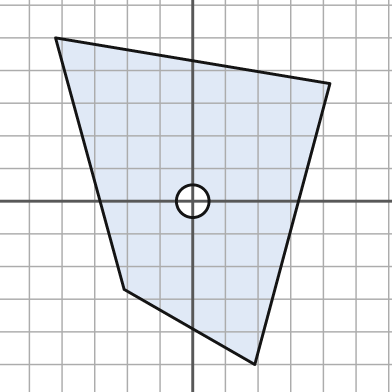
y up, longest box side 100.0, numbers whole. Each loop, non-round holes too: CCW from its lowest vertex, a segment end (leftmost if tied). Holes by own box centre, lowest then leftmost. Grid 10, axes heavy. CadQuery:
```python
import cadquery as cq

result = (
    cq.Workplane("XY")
    .moveTo(19.0, -50.0)
    .lineTo(42.0, 36.0)
    .lineTo(-42.0, 50.0)
    .lineTo(-21.0, -27.0)
    .close()
    .moveTo(0.0, 0.0)
    .circle(5.0)
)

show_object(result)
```